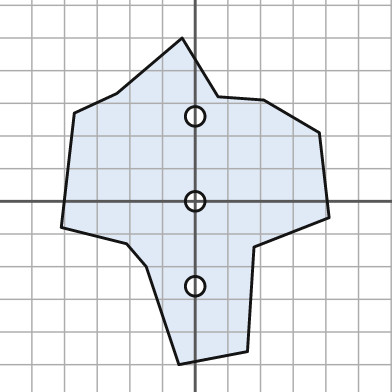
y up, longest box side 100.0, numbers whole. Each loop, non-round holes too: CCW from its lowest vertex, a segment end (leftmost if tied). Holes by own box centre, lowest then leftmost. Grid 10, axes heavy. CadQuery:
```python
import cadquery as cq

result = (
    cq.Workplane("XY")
    .moveTo(-5.0, -50.0)
    .lineTo(16.0, -46.0)
    .lineTo(18.0, -14.0)
    .lineTo(41.0, -5.0)
    .lineTo(38.0, 21.0)
    .lineTo(21.0, 31.0)
    .lineTo(7.0, 32.0)
    .lineTo(-4.0, 50.0)
    .lineTo(-24.0, 33.0)
    .lineTo(-37.0, 27.0)
    .lineTo(-41.0, -8.0)
    .lineTo(-21.0, -13.0)
    .lineTo(-15.0, -20.0)
    .close()
    .moveTo(0.0, -26.0)
    .circle(3.0)
    .moveTo(0.0, 0.0)
    .circle(3.0)
    .moveTo(0.0, 26.0)
    .circle(3.0)
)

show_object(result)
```